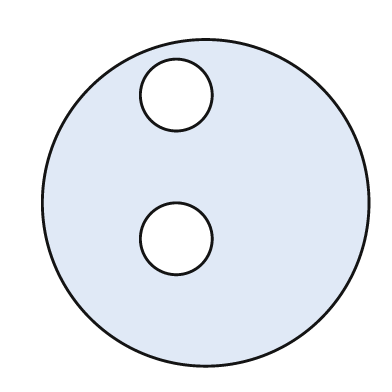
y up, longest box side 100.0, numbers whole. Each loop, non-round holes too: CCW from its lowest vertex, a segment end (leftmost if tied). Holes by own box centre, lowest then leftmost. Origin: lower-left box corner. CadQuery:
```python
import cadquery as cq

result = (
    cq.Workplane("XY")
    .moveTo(50.0, 50.0)
    .circle(50.0)
    .moveTo(41.0, 39.0)
    .circle(11.0)
    .moveTo(41.0, 83.0)
    .circle(11.0)
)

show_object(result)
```